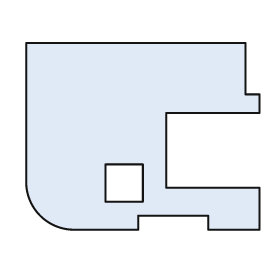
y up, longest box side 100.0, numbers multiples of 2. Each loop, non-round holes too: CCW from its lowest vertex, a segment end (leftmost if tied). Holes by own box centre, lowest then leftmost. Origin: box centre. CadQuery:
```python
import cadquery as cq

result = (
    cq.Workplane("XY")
    .moveTo(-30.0, -40.0)
    .lineTo(-2.0, -40.0)
    .lineTo(-2.0, -34.0)
    .lineTo(28.0, -34.0)
    .lineTo(28.0, -40.0)
    .lineTo(50.0, -40.0)
    .lineTo(50.0, -22.0)
    .lineTo(10.0, -22.0)
    .lineTo(10.0, 10.0)
    .lineTo(50.0, 10.0)
    .lineTo(50.0, 18.0)
    .lineTo(44.0, 18.0)
    .lineTo(44.0, 40.0)
    .lineTo(-50.0, 40.0)
    .lineTo(-50.0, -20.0)
    .threePointArc((-44.0, -34.0), (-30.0, -40.0))
    .close()
    .moveTo(-16.0, -28.0)
    .lineTo(0.0, -28.0)
    .lineTo(0.0, -12.0)
    .lineTo(-16.0, -12.0)
    .close()
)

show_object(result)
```